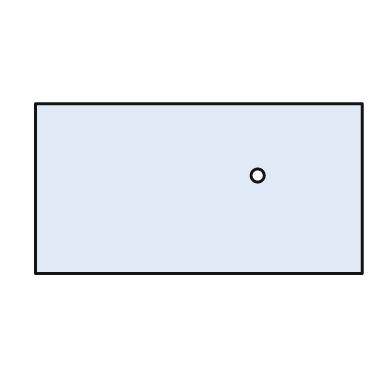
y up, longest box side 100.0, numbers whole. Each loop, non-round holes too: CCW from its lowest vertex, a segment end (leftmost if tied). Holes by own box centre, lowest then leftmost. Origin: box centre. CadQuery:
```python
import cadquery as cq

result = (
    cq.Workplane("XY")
    .moveTo(-50.0, -26.0)
    .lineTo(50.0, -26.0)
    .lineTo(50.0, 26.0)
    .lineTo(-50.0, 26.0)
    .close()
    .moveTo(18.0, 4.0)
    .circle(2.0)
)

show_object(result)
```